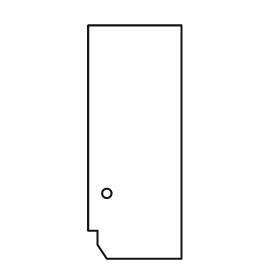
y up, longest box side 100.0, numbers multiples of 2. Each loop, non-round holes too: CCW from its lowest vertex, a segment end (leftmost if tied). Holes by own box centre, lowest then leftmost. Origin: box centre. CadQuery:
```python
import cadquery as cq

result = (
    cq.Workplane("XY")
    .moveTo(-12.0, -50.0)
    .lineTo(20.0, -50.0)
    .lineTo(20.0, 50.0)
    .lineTo(-20.0, 50.0)
    .lineTo(-20.0, -38.0)
    .lineTo(-16.0, -38.0)
    .lineTo(-16.0, -44.0)
    .close()
    .moveTo(-12.0, -22.0)
    .circle(2.0)
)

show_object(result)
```